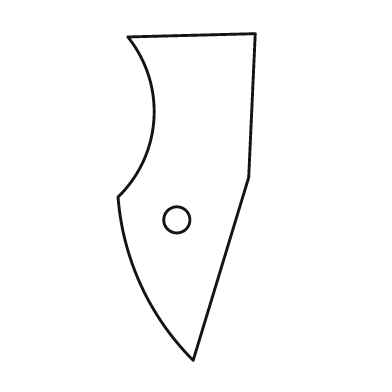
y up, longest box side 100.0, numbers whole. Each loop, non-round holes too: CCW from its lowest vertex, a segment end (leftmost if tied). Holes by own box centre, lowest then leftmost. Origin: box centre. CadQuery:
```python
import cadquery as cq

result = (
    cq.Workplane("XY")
    .moveTo(2.0, -50.0)
    .lineTo(19.0, 6.0)
    .lineTo(21.0, 50.0)
    .lineTo(-18.0, 49.0)
    .threePointArc((-10.0, 24.0), (-21.0, 0.0))
    .threePointArc((-14.0, -27.0), (2.0, -50.0))
    .close()
    .moveTo(-3.0, -7.0)
    .circle(4.0)
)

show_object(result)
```